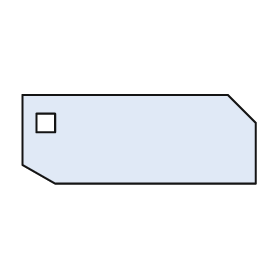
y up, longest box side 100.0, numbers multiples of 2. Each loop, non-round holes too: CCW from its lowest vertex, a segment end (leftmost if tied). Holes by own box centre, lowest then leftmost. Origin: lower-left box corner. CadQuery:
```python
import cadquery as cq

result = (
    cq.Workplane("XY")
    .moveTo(14.0, 0.0)
    .lineTo(100.0, 0.0)
    .lineTo(100.0, 26.0)
    .lineTo(88.0, 38.0)
    .lineTo(0.0, 38.0)
    .lineTo(0.0, 8.0)
    .close()
    .moveTo(6.0, 22.0)
    .lineTo(14.0, 22.0)
    .lineTo(14.0, 30.0)
    .lineTo(6.0, 30.0)
    .close()
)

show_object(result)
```